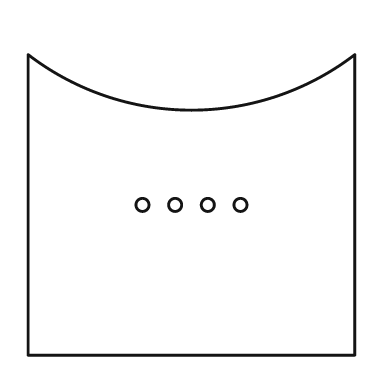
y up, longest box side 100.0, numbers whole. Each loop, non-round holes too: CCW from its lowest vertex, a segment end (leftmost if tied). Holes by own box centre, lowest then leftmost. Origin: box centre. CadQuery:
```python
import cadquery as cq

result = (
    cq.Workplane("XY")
    .moveTo(-50.0, -46.0)
    .lineTo(50.0, -46.0)
    .lineTo(50.0, 46.0)
    .threePointArc((0.0, 29.0), (-50.0, 46.0))
    .close()
    .moveTo(-15.0, 0.0)
    .circle(2.0)
    .moveTo(-5.0, 0.0)
    .circle(2.0)
    .moveTo(5.0, 0.0)
    .circle(2.0)
    .moveTo(15.0, 0.0)
    .circle(2.0)
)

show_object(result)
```